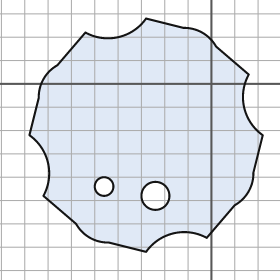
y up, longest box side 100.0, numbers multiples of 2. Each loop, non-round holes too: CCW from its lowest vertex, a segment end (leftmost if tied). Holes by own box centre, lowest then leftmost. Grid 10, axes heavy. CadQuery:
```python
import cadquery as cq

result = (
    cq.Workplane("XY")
    .moveTo(-28.0, -72.0)
    .threePointArc((-16.0, -64.0), (-2.0, -66.0))
    .lineTo(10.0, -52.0)
    .threePointArc((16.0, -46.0), (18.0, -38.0))
    .lineTo(22.0, -22.0)
    .threePointArc((14.0, -10.0), (16.0, 4.0))
    .lineTo(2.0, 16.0)
    .threePointArc((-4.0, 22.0), (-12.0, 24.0))
    .lineTo(-28.0, 28.0)
    .threePointArc((-40.0, 20.0), (-54.0, 22.0))
    .lineTo(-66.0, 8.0)
    .threePointArc((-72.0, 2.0), (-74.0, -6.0))
    .lineTo(-78.0, -22.0)
    .threePointArc((-70.0, -34.0), (-72.0, -48.0))
    .lineTo(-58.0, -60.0)
    .threePointArc((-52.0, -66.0), (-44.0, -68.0))
    .close()
    .moveTo(-24.0, -48.0)
    .circle(6.0)
    .moveTo(-46.0, -44.0)
    .circle(4.0)
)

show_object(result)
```